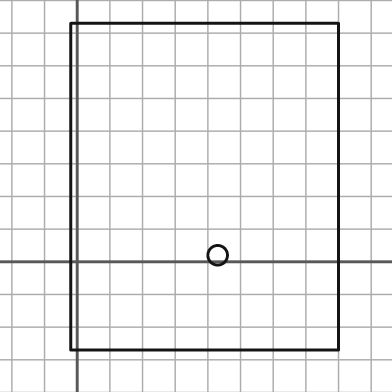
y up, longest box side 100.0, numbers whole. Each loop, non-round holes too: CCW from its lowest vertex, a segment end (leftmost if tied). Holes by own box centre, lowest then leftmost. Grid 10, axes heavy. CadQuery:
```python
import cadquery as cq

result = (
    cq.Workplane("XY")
    .moveTo(-2.0, -27.0)
    .lineTo(80.0, -27.0)
    .lineTo(80.0, 73.0)
    .lineTo(-2.0, 73.0)
    .close()
    .moveTo(43.0, 2.0)
    .circle(3.0)
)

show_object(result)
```